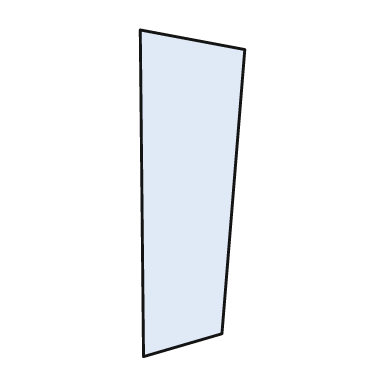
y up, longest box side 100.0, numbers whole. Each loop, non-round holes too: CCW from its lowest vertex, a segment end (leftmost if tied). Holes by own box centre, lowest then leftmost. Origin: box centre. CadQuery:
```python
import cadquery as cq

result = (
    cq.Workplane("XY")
    .moveTo(-15.0, -50.0)
    .lineTo(9.0, -43.0)
    .lineTo(16.0, 44.0)
    .lineTo(-16.0, 50.0)
    .close()
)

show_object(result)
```